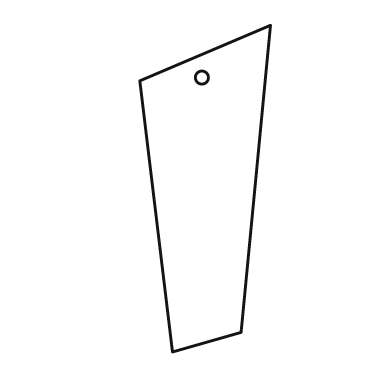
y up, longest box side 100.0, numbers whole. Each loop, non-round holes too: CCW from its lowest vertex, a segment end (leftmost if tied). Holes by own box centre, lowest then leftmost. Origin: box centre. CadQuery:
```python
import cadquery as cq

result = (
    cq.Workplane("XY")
    .moveTo(-10.0, -50.0)
    .lineTo(11.0, -44.0)
    .lineTo(20.0, 50.0)
    .lineTo(-20.0, 33.0)
    .close()
    .moveTo(-1.0, 34.0)
    .circle(2.0)
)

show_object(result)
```